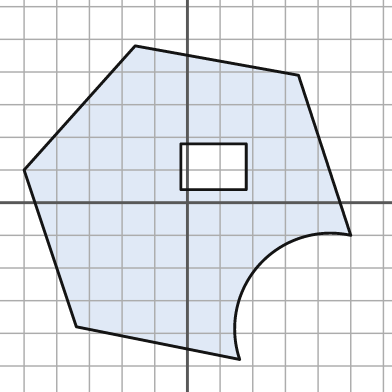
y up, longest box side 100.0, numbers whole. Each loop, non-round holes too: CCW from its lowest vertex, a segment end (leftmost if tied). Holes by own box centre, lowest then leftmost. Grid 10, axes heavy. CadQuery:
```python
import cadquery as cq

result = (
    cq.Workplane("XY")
    .moveTo(16.0, -48.0)
    .threePointArc((22.0, -19.0), (50.0, -10.0))
    .lineTo(34.0, 39.0)
    .lineTo(-16.0, 48.0)
    .lineTo(-50.0, 10.0)
    .lineTo(-34.0, -38.0)
    .close()
    .moveTo(-2.0, 4.0)
    .lineTo(18.0, 4.0)
    .lineTo(18.0, 18.0)
    .lineTo(-2.0, 18.0)
    .close()
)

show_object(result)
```